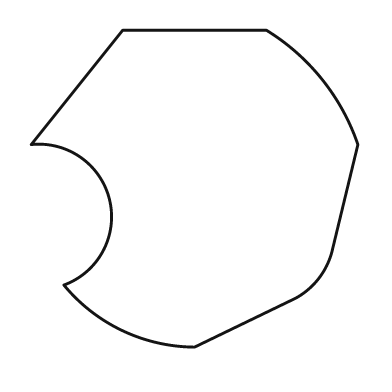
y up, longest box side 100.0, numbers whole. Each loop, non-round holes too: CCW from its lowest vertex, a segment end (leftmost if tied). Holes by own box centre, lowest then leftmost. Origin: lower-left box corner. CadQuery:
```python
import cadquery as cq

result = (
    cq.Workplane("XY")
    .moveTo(50.0, 0.0)
    .lineTo(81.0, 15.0)
    .threePointArc((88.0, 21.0), (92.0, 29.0))
    .lineTo(100.0, 62.0)
    .threePointArc((89.0, 82.0), (72.0, 97.0))
    .lineTo(28.0, 97.0)
    .lineTo(0.0, 62.0)
    .threePointArc((24.0, 45.0), (10.0, 19.0))
    .threePointArc((28.0, 5.0), (50.0, 0.0))
    .close()
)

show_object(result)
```